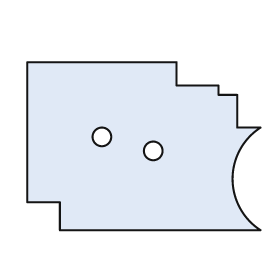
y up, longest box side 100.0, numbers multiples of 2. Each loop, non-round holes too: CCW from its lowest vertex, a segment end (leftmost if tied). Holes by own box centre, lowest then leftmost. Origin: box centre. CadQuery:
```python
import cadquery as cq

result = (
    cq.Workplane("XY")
    .moveTo(-36.0, -36.0)
    .lineTo(50.0, -36.0)
    .threePointArc((38.0, -14.0), (50.0, 8.0))
    .lineTo(40.0, 8.0)
    .lineTo(40.0, 22.0)
    .lineTo(32.0, 22.0)
    .lineTo(32.0, 26.0)
    .lineTo(14.0, 26.0)
    .lineTo(14.0, 36.0)
    .lineTo(-50.0, 36.0)
    .lineTo(-50.0, -24.0)
    .lineTo(-36.0, -24.0)
    .close()
    .moveTo(4.0, -2.0)
    .circle(4.0)
    .moveTo(-18.0, 4.0)
    .circle(4.0)
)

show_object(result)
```